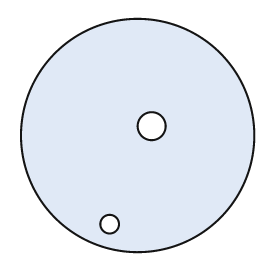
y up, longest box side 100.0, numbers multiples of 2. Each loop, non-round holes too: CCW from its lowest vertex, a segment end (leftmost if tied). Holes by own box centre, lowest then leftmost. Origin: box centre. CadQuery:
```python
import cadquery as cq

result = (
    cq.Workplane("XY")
    .moveTo(0.0, 0.0)
    .circle(50.0)
    .moveTo(-12.0, -38.0)
    .circle(4.0)
    .moveTo(6.0, 4.0)
    .circle(6.0)
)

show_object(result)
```